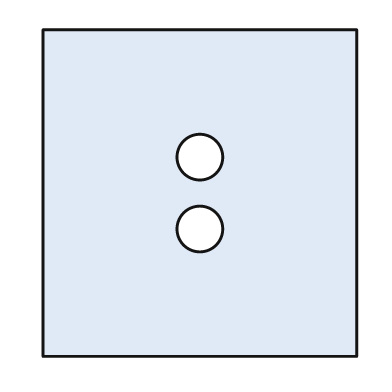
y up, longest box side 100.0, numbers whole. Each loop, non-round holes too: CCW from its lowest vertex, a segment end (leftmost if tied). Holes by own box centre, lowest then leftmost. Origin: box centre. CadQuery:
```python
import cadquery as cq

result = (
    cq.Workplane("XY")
    .moveTo(-48.0, -50.0)
    .lineTo(48.0, -50.0)
    .lineTo(48.0, 50.0)
    .lineTo(-48.0, 50.0)
    .close()
    .moveTo(0.0, -11.0)
    .circle(7.0)
    .moveTo(0.0, 11.0)
    .circle(7.0)
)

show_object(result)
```